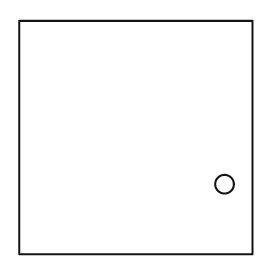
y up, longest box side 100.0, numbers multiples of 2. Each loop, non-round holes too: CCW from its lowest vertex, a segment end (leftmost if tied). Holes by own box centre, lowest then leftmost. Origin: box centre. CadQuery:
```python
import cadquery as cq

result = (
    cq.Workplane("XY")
    .moveTo(-50.0, -50.0)
    .lineTo(50.0, -50.0)
    .lineTo(50.0, 50.0)
    .lineTo(-50.0, 50.0)
    .close()
    .moveTo(38.0, -20.0)
    .circle(4.0)
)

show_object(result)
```